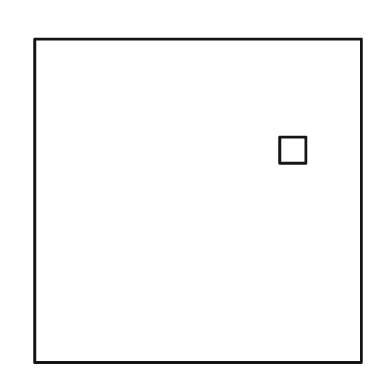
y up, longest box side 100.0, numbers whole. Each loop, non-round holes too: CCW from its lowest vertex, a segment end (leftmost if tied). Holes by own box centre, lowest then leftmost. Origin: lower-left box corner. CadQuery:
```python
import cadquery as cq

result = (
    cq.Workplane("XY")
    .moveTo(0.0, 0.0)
    .lineTo(100.0, 0.0)
    .lineTo(100.0, 99.0)
    .lineTo(0.0, 99.0)
    .close()
    .moveTo(75.0, 61.0)
    .lineTo(83.0, 61.0)
    .lineTo(83.0, 69.0)
    .lineTo(75.0, 69.0)
    .close()
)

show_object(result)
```